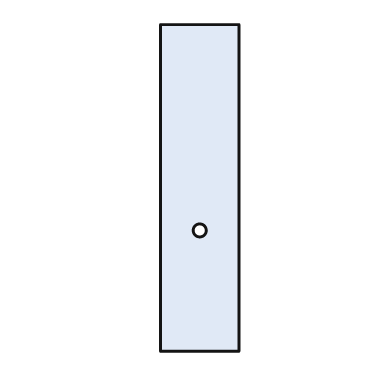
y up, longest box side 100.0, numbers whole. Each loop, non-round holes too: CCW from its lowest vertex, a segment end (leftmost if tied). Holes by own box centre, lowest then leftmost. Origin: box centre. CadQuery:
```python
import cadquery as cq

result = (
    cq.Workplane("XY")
    .moveTo(-12.0, -50.0)
    .lineTo(12.0, -50.0)
    .lineTo(12.0, 50.0)
    .lineTo(-12.0, 50.0)
    .close()
    .moveTo(0.0, -13.0)
    .circle(2.0)
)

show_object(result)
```